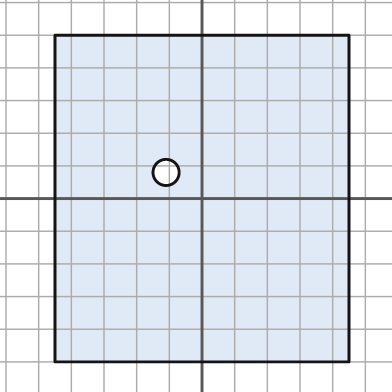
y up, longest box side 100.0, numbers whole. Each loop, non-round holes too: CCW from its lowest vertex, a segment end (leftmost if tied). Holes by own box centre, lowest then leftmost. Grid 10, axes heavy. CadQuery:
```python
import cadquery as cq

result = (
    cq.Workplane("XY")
    .moveTo(-45.0, -50.0)
    .lineTo(45.0, -50.0)
    .lineTo(45.0, 50.0)
    .lineTo(-45.0, 50.0)
    .close()
    .moveTo(-11.0, 8.0)
    .circle(4.0)
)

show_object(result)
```